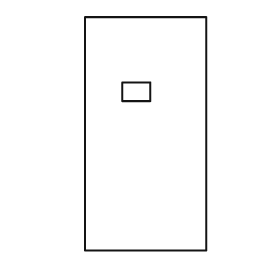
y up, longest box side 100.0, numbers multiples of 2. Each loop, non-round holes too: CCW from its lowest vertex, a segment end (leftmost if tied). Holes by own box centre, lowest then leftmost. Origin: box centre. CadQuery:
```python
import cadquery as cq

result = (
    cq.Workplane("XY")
    .moveTo(-26.0, -50.0)
    .lineTo(26.0, -50.0)
    .lineTo(26.0, 50.0)
    .lineTo(-26.0, 50.0)
    .close()
    .moveTo(-10.0, 14.0)
    .lineTo(2.0, 14.0)
    .lineTo(2.0, 22.0)
    .lineTo(-10.0, 22.0)
    .close()
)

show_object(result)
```